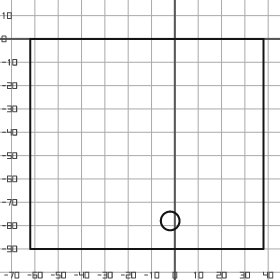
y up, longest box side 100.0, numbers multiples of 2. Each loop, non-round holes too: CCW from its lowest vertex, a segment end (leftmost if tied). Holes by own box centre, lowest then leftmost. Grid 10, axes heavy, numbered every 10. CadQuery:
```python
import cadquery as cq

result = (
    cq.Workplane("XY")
    .moveTo(-62.0, -90.0)
    .lineTo(38.0, -90.0)
    .lineTo(38.0, 0.0)
    .lineTo(-62.0, 0.0)
    .close()
    .moveTo(-2.0, -78.0)
    .circle(4.0)
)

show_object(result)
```